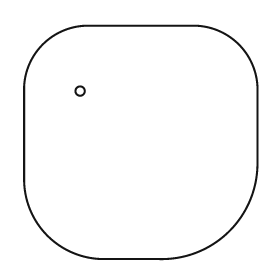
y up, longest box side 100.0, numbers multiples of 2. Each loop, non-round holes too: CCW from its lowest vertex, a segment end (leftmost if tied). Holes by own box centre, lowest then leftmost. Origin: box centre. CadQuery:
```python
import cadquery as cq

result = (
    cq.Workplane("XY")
    .moveTo(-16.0, -50.0)
    .lineTo(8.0, -50.0)
    .threePointArc((38.0, -38.0), (50.0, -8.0))
    .lineTo(50.0, 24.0)
    .threePointArc((42.0, 42.0), (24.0, 50.0))
    .lineTo(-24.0, 50.0)
    .threePointArc((-42.0, 42.0), (-50.0, 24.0))
    .lineTo(-50.0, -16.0)
    .threePointArc((-40.0, -40.0), (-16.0, -50.0))
    .close()
    .moveTo(-26.0, 22.0)
    .circle(2.0)
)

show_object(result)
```